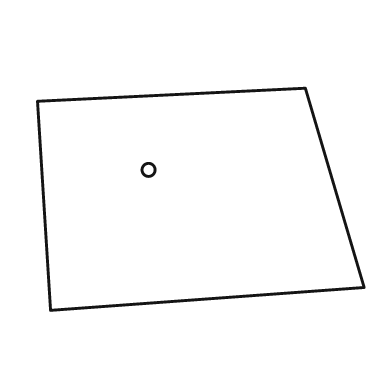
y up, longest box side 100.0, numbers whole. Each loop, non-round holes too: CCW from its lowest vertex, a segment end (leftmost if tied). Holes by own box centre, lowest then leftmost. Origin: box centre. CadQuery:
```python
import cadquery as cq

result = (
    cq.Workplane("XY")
    .moveTo(-46.0, -34.0)
    .lineTo(50.0, -27.0)
    .lineTo(32.0, 34.0)
    .lineTo(-50.0, 30.0)
    .close()
    .moveTo(-16.0, 9.0)
    .circle(2.0)
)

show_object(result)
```